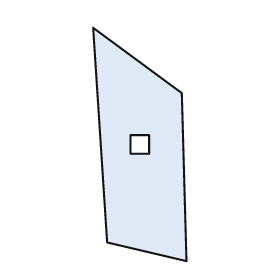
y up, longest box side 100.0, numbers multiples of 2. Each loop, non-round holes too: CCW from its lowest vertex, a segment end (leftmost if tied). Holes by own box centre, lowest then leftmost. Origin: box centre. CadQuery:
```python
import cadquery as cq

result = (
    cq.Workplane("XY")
    .moveTo(20.0, -50.0)
    .lineTo(18.0, 22.0)
    .lineTo(-20.0, 50.0)
    .lineTo(-14.0, -42.0)
    .close()
    .moveTo(-4.0, -4.0)
    .lineTo(4.0, -4.0)
    .lineTo(4.0, 4.0)
    .lineTo(-4.0, 4.0)
    .close()
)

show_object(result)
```